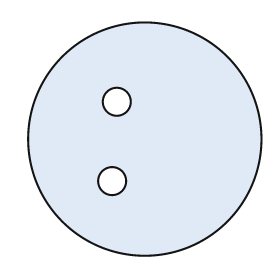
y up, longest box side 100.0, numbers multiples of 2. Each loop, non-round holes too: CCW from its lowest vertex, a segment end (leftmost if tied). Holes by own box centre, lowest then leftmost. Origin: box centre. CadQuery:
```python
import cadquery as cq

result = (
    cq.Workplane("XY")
    .moveTo(0.0, 0.0)
    .circle(50.0)
    .moveTo(-14.0, -18.0)
    .circle(6.0)
    .moveTo(-12.0, 16.0)
    .circle(6.0)
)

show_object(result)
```